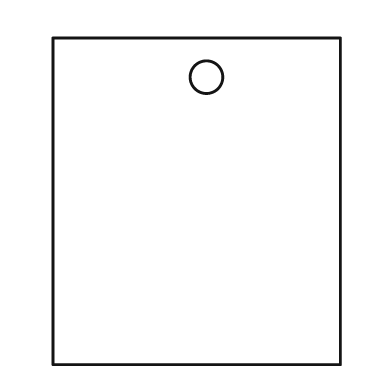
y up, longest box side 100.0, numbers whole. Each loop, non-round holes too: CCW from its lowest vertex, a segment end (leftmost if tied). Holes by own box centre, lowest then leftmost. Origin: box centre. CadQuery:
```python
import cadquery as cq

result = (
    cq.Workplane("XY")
    .moveTo(-44.0, -50.0)
    .lineTo(44.0, -50.0)
    .lineTo(44.0, 50.0)
    .lineTo(-44.0, 50.0)
    .close()
    .moveTo(3.0, 38.0)
    .circle(5.0)
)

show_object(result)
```